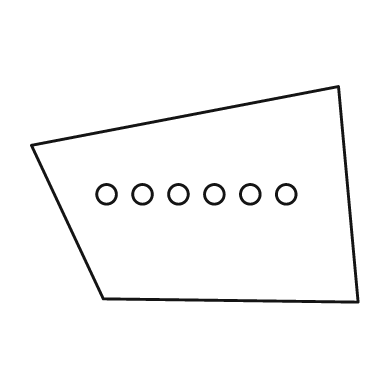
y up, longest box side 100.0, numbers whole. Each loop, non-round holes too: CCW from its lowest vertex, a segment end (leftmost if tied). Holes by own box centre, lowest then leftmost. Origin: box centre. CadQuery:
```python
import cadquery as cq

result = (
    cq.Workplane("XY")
    .moveTo(50.0, -33.0)
    .lineTo(44.0, 33.0)
    .lineTo(-50.0, 15.0)
    .lineTo(-28.0, -32.0)
    .close()
    .moveTo(-27.0, 0.0)
    .circle(3.0)
    .moveTo(-16.0, 0.0)
    .circle(3.0)
    .moveTo(-5.0, 0.0)
    .circle(3.0)
    .moveTo(6.0, 0.0)
    .circle(3.0)
    .moveTo(17.0, 0.0)
    .circle(3.0)
    .moveTo(28.0, 0.0)
    .circle(3.0)
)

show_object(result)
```